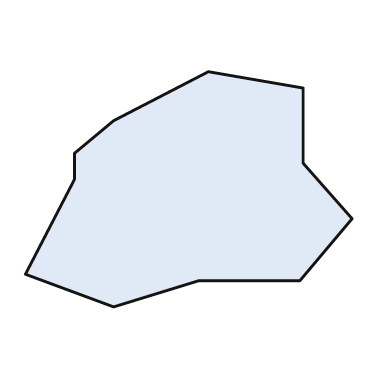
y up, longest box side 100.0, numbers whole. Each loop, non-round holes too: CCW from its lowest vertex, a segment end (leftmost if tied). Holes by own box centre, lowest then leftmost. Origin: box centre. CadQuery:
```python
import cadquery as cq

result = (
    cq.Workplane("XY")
    .moveTo(-23.0, -36.0)
    .lineTo(3.0, -28.0)
    .lineTo(34.0, -28.0)
    .lineTo(50.0, -9.0)
    .lineTo(35.0, 8.0)
    .lineTo(35.0, 31.0)
    .lineTo(6.0, 36.0)
    .lineTo(-23.0, 21.0)
    .lineTo(-35.0, 11.0)
    .lineTo(-35.0, 3.0)
    .lineTo(-50.0, -26.0)
    .close()
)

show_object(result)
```